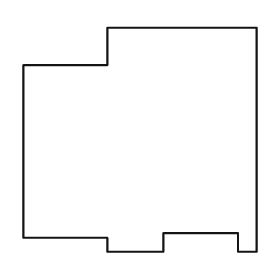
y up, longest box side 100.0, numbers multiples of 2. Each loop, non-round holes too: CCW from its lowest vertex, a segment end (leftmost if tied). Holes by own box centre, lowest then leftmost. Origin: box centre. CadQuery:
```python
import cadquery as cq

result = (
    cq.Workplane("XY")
    .moveTo(-14.0, -48.0)
    .lineTo(10.0, -48.0)
    .lineTo(10.0, -40.0)
    .lineTo(42.0, -40.0)
    .lineTo(42.0, -48.0)
    .lineTo(50.0, -48.0)
    .lineTo(50.0, 48.0)
    .lineTo(-14.0, 48.0)
    .lineTo(-14.0, 32.0)
    .lineTo(-50.0, 32.0)
    .lineTo(-50.0, -42.0)
    .lineTo(-14.0, -42.0)
    .close()
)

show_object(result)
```